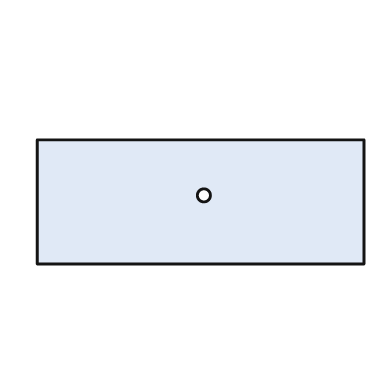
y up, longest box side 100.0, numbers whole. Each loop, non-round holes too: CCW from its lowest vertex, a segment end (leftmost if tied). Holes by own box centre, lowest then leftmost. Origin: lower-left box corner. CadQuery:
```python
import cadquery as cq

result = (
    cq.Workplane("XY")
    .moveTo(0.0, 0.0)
    .lineTo(100.0, 0.0)
    .lineTo(100.0, 38.0)
    .lineTo(0.0, 38.0)
    .close()
    .moveTo(51.0, 21.0)
    .circle(2.0)
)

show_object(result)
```